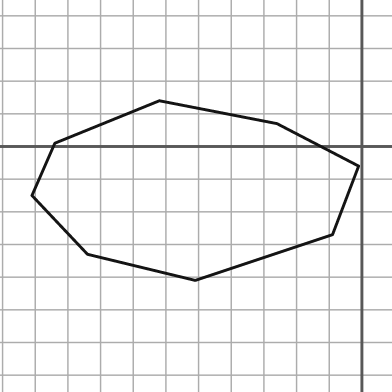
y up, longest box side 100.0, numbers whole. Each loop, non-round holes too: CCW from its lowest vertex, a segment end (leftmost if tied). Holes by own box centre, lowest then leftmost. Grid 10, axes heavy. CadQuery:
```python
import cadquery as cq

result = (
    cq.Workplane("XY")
    .moveTo(-51.0, -41.0)
    .lineTo(-9.0, -27.0)
    .lineTo(-1.0, -6.0)
    .lineTo(-26.0, 7.0)
    .lineTo(-62.0, 14.0)
    .lineTo(-94.0, 1.0)
    .lineTo(-101.0, -15.0)
    .lineTo(-84.0, -33.0)
    .close()
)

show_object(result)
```